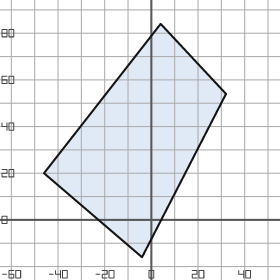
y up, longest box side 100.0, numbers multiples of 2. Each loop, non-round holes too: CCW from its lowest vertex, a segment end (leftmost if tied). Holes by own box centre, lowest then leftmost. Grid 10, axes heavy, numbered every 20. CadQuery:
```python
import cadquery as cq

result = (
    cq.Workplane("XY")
    .moveTo(-4.0, -16.0)
    .lineTo(32.0, 54.0)
    .lineTo(4.0, 84.0)
    .lineTo(-46.0, 20.0)
    .close()
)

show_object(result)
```